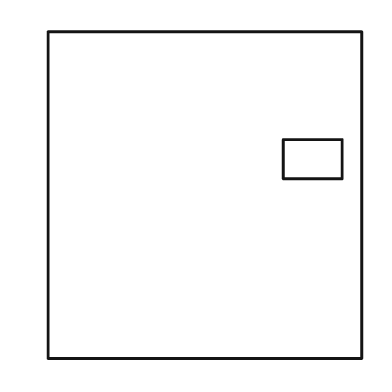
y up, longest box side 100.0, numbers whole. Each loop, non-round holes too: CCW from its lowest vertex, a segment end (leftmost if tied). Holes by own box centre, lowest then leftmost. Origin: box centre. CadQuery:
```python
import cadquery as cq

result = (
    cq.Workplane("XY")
    .moveTo(-48.0, -50.0)
    .lineTo(48.0, -50.0)
    .lineTo(48.0, 50.0)
    .lineTo(-48.0, 50.0)
    .close()
    .moveTo(24.0, 5.0)
    .lineTo(42.0, 5.0)
    .lineTo(42.0, 17.0)
    .lineTo(24.0, 17.0)
    .close()
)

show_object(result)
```